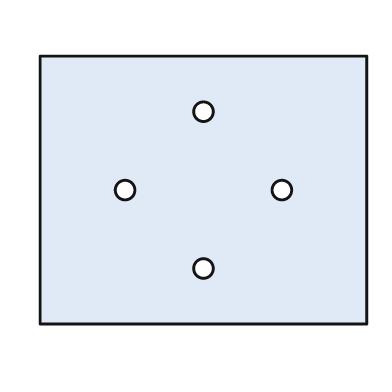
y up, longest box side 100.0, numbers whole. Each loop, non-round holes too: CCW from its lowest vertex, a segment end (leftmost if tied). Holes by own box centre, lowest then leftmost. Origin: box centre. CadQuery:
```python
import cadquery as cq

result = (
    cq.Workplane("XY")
    .moveTo(-50.0, -41.0)
    .lineTo(50.0, -41.0)
    .lineTo(50.0, 41.0)
    .lineTo(-50.0, 41.0)
    .close()
    .moveTo(0.0, -24.0)
    .circle(3.0)
    .moveTo(-24.0, 0.0)
    .circle(3.0)
    .moveTo(24.0, 0.0)
    .circle(3.0)
    .moveTo(0.0, 24.0)
    .circle(3.0)
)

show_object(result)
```